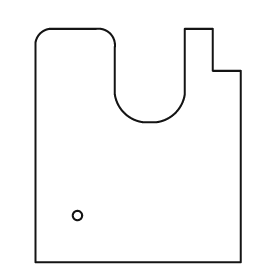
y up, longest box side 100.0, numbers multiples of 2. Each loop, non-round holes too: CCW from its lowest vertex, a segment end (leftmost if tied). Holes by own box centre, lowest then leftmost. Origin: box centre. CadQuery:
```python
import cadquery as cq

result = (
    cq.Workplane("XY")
    .moveTo(-44.0, -50.0)
    .lineTo(44.0, -50.0)
    .lineTo(44.0, 32.0)
    .lineTo(32.0, 32.0)
    .lineTo(32.0, 50.0)
    .lineTo(20.0, 50.0)
    .lineTo(20.0, 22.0)
    .threePointArc((16.0, 14.0), (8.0, 10.0))
    .lineTo(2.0, 10.0)
    .threePointArc((-6.0, 14.0), (-10.0, 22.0))
    .lineTo(-10.0, 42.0)
    .threePointArc((-12.0, 48.0), (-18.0, 50.0))
    .lineTo(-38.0, 50.0)
    .threePointArc((-42.0, 48.0), (-44.0, 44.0))
    .close()
    .moveTo(-26.0, -30.0)
    .circle(2.0)
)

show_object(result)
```